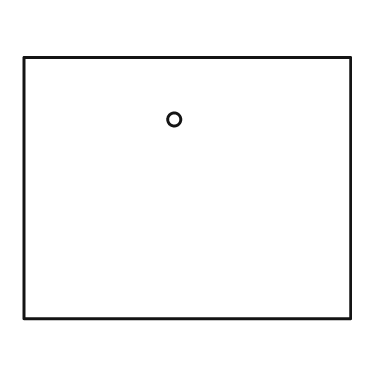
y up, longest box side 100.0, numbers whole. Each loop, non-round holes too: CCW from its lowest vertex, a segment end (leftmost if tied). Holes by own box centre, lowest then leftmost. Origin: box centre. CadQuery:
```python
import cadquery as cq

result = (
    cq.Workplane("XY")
    .moveTo(-50.0, -40.0)
    .lineTo(50.0, -40.0)
    .lineTo(50.0, 40.0)
    .lineTo(-50.0, 40.0)
    .close()
    .moveTo(-4.0, 21.0)
    .circle(2.0)
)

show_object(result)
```